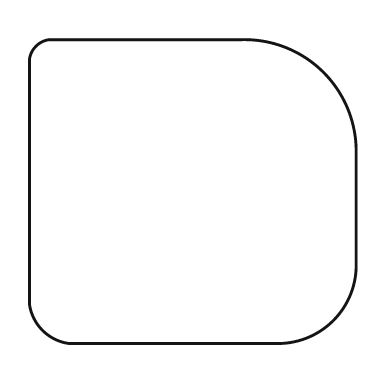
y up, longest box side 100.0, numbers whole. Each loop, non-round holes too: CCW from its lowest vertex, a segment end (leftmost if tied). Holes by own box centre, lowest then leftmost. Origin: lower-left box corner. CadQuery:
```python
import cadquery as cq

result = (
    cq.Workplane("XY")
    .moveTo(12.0, 0.0)
    .lineTo(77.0, 0.0)
    .threePointArc((93.0, 7.0), (100.0, 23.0))
    .lineTo(100.0, 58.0)
    .threePointArc((90.0, 83.0), (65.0, 93.0))
    .lineTo(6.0, 93.0)
    .threePointArc((2.0, 91.0), (0.0, 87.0))
    .lineTo(0.0, 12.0)
    .threePointArc((4.0, 4.0), (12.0, 0.0))
    .close()
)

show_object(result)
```